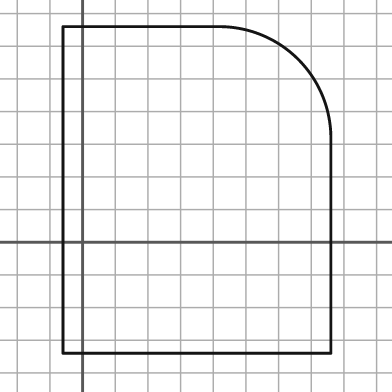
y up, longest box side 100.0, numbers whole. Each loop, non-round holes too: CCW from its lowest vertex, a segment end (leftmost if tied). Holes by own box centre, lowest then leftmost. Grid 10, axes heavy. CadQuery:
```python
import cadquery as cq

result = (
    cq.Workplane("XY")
    .moveTo(-6.0, -34.0)
    .lineTo(76.0, -34.0)
    .lineTo(76.0, 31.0)
    .threePointArc((66.0, 56.0), (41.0, 66.0))
    .lineTo(-6.0, 66.0)
    .close()
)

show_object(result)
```